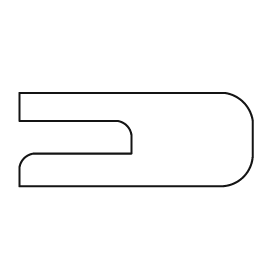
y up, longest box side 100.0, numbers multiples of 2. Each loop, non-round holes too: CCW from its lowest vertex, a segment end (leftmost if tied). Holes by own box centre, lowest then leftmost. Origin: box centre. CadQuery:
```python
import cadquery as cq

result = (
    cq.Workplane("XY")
    .moveTo(-50.0, -20.0)
    .lineTo(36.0, -20.0)
    .threePointArc((46.0, -16.0), (50.0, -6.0))
    .lineTo(50.0, 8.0)
    .threePointArc((46.0, 16.0), (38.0, 20.0))
    .lineTo(-50.0, 20.0)
    .lineTo(-50.0, 8.0)
    .lineTo(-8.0, 8.0)
    .threePointArc((-4.0, 6.0), (-2.0, 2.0))
    .lineTo(-2.0, -6.0)
    .lineTo(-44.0, -6.0)
    .threePointArc((-48.0, -8.0), (-50.0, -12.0))
    .close()
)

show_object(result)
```